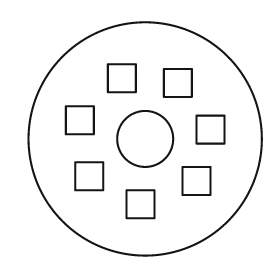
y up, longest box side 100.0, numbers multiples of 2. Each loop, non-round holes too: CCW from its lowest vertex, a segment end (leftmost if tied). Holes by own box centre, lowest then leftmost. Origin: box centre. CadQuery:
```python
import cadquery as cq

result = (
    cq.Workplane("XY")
    .moveTo(0.0, 0.0)
    .circle(50.0)
    .moveTo(-8.0, -34.0)
    .lineTo(4.0, -34.0)
    .lineTo(4.0, -22.0)
    .lineTo(-8.0, -22.0)
    .close()
    .moveTo(16.0, -24.0)
    .lineTo(28.0, -24.0)
    .lineTo(28.0, -12.0)
    .lineTo(16.0, -12.0)
    .close()
    .moveTo(-30.0, -22.0)
    .lineTo(-18.0, -22.0)
    .lineTo(-18.0, -10.0)
    .lineTo(-30.0, -10.0)
    .close()
    .moveTo(0.0, 0.0)
    .circle(12.0)
    .moveTo(22.0, -2.0)
    .lineTo(34.0, -2.0)
    .lineTo(34.0, 10.0)
    .lineTo(22.0, 10.0)
    .close()
    .moveTo(-34.0, 2.0)
    .lineTo(-22.0, 2.0)
    .lineTo(-22.0, 14.0)
    .lineTo(-34.0, 14.0)
    .close()
    .moveTo(8.0, 18.0)
    .lineTo(20.0, 18.0)
    .lineTo(20.0, 30.0)
    .lineTo(8.0, 30.0)
    .close()
    .moveTo(-16.0, 20.0)
    .lineTo(-4.0, 20.0)
    .lineTo(-4.0, 32.0)
    .lineTo(-16.0, 32.0)
    .close()
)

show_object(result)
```